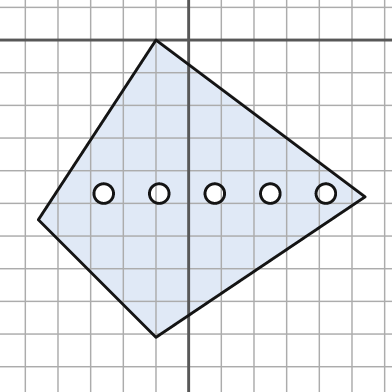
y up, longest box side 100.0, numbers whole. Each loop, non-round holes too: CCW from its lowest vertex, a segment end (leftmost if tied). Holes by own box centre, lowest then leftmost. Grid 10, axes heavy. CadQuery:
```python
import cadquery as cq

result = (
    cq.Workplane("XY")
    .moveTo(-10.0, -91.0)
    .lineTo(54.0, -48.0)
    .lineTo(-10.0, 0.0)
    .lineTo(-46.0, -55.0)
    .close()
    .moveTo(-26.0, -47.0)
    .circle(3.0)
    .moveTo(-9.0, -47.0)
    .circle(3.0)
    .moveTo(8.0, -47.0)
    .circle(3.0)
    .moveTo(25.0, -47.0)
    .circle(3.0)
    .moveTo(42.0, -47.0)
    .circle(3.0)
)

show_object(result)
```